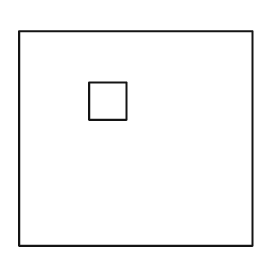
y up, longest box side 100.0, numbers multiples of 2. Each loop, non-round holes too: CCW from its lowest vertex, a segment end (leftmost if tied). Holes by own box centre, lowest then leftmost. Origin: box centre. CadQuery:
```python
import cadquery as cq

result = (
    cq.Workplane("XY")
    .moveTo(-50.0, -46.0)
    .lineTo(50.0, -46.0)
    .lineTo(50.0, 46.0)
    .lineTo(-50.0, 46.0)
    .close()
    .moveTo(-20.0, 8.0)
    .lineTo(-4.0, 8.0)
    .lineTo(-4.0, 24.0)
    .lineTo(-20.0, 24.0)
    .close()
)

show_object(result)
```